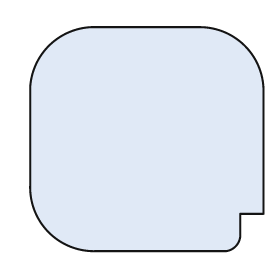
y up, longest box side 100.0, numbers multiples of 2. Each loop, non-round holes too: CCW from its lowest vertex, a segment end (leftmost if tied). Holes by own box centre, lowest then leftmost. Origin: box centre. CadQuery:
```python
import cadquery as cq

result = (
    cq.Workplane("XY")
    .moveTo(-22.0, -48.0)
    .lineTo(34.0, -48.0)
    .threePointArc((38.0, -46.0), (40.0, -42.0))
    .lineTo(40.0, -32.0)
    .lineTo(50.0, -32.0)
    .lineTo(50.0, 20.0)
    .threePointArc((42.0, 40.0), (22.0, 48.0))
    .lineTo(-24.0, 48.0)
    .threePointArc((-42.0, 40.0), (-50.0, 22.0))
    .lineTo(-50.0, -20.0)
    .threePointArc((-42.0, -40.0), (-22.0, -48.0))
    .close()
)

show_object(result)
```